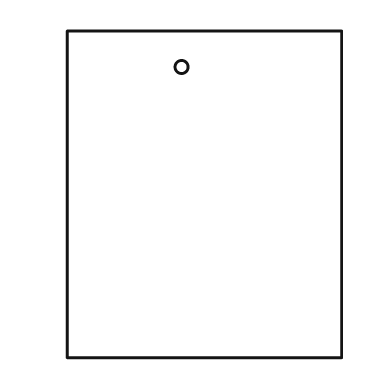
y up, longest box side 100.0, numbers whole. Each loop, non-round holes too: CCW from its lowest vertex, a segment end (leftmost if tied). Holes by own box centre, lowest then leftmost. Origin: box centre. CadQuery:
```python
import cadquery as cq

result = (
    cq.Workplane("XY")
    .moveTo(-42.0, -50.0)
    .lineTo(42.0, -50.0)
    .lineTo(42.0, 50.0)
    .lineTo(-42.0, 50.0)
    .close()
    .moveTo(-7.0, 39.0)
    .circle(2.0)
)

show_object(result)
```